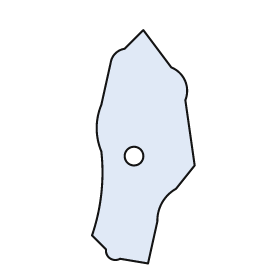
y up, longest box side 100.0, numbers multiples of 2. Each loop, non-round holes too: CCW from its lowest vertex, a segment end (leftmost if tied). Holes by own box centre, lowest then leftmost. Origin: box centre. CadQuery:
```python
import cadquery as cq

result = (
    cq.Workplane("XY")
    .moveTo(2.0, -50.0)
    .lineTo(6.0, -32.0)
    .threePointArc((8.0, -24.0), (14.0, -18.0))
    .lineTo(22.0, -8.0)
    .lineTo(18.0, 20.0)
    .threePointArc((18.0, 28.0), (12.0, 34.0))
    .lineTo(0.0, 50.0)
    .lineTo(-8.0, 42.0)
    .threePointArc((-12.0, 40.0), (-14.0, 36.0))
    .lineTo(-18.0, 18.0)
    .threePointArc((-20.0, 8.0), (-18.0, -2.0))
    .threePointArc((-18.0, -20.0), (-22.0, -38.0))
    .lineTo(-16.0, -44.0)
    .threePointArc((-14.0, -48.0), (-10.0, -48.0))
    .close()
    .moveTo(-4.0, -4.0)
    .circle(4.0)
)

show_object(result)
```